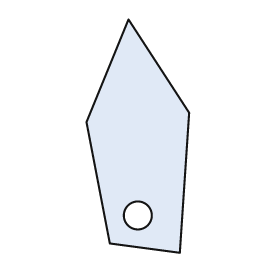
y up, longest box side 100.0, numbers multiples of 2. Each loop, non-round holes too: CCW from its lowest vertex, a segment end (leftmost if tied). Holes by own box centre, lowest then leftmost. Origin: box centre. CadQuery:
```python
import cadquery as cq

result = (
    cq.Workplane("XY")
    .moveTo(18.0, -50.0)
    .lineTo(22.0, 10.0)
    .lineTo(-4.0, 50.0)
    .lineTo(-22.0, 6.0)
    .lineTo(-12.0, -46.0)
    .close()
    .moveTo(0.0, -34.0)
    .circle(6.0)
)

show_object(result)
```